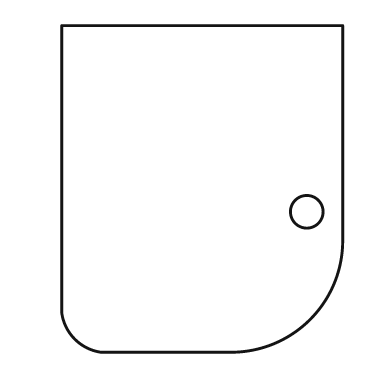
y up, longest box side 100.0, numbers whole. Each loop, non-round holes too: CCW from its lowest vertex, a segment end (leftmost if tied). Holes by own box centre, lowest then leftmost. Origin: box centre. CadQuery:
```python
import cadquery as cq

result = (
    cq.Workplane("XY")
    .moveTo(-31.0, -50.0)
    .lineTo(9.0, -50.0)
    .threePointArc((33.0, -40.0), (43.0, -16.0))
    .lineTo(43.0, 50.0)
    .lineTo(-43.0, 50.0)
    .lineTo(-43.0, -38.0)
    .threePointArc((-39.0, -46.0), (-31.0, -50.0))
    .close()
    .moveTo(32.0, -7.0)
    .circle(5.0)
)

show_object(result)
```